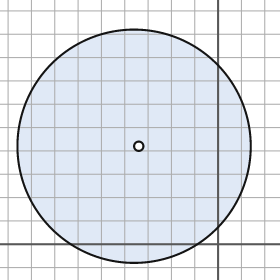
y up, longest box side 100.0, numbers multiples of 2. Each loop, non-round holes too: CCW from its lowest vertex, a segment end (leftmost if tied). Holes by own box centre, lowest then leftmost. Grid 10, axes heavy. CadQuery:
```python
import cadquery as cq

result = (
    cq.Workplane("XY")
    .moveTo(-36.0, 42.0)
    .circle(50.0)
    .moveTo(-34.0, 42.0)
    .circle(2.0)
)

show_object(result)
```